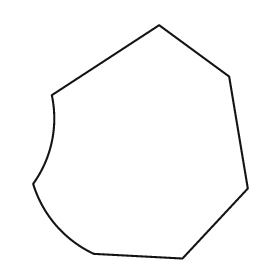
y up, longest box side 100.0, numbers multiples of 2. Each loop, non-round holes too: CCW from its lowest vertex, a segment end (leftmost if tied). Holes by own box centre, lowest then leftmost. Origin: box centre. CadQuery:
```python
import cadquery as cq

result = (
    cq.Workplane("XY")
    .moveTo(18.0, -50.0)
    .lineTo(46.0, -20.0)
    .lineTo(38.0, 28.0)
    .lineTo(8.0, 50.0)
    .lineTo(-38.0, 20.0)
    .threePointArc((-38.0, 0.0), (-46.0, -18.0))
    .threePointArc((-36.0, -36.0), (-20.0, -48.0))
    .close()
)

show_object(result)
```